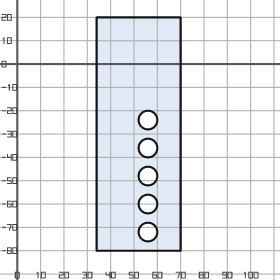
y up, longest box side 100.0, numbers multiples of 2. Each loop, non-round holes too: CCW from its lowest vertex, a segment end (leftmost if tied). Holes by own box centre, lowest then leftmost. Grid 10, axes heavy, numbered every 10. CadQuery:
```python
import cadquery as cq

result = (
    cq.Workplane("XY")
    .moveTo(34.0, -80.0)
    .lineTo(70.0, -80.0)
    .lineTo(70.0, 20.0)
    .lineTo(34.0, 20.0)
    .close()
    .moveTo(56.0, -72.0)
    .circle(4.0)
    .moveTo(56.0, -60.0)
    .circle(4.0)
    .moveTo(56.0, -48.0)
    .circle(4.0)
    .moveTo(56.0, -36.0)
    .circle(4.0)
    .moveTo(56.0, -24.0)
    .circle(4.0)
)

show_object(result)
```